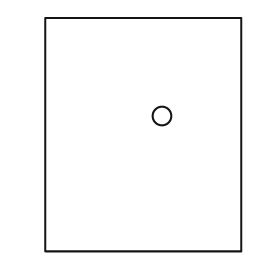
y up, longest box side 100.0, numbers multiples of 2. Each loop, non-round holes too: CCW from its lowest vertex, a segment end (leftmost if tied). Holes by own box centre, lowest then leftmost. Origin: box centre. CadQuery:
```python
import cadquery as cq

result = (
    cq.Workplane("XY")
    .moveTo(-42.0, -50.0)
    .lineTo(42.0, -50.0)
    .lineTo(42.0, 50.0)
    .lineTo(-42.0, 50.0)
    .close()
    .moveTo(8.0, 8.0)
    .circle(4.0)
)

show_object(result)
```